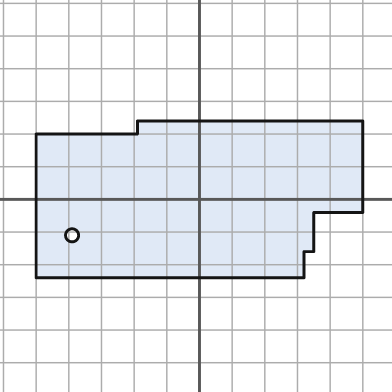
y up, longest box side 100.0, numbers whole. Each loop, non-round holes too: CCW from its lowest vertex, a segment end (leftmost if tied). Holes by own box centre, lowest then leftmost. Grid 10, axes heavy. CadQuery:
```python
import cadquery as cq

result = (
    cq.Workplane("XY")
    .moveTo(-50.0, -24.0)
    .lineTo(32.0, -24.0)
    .lineTo(32.0, -16.0)
    .lineTo(35.0, -16.0)
    .lineTo(35.0, -4.0)
    .lineTo(50.0, -4.0)
    .lineTo(50.0, 24.0)
    .lineTo(-19.0, 24.0)
    .lineTo(-19.0, 20.0)
    .lineTo(-50.0, 20.0)
    .close()
    .moveTo(-39.0, -11.0)
    .circle(2.0)
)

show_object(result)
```